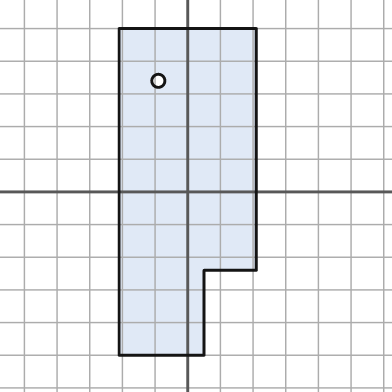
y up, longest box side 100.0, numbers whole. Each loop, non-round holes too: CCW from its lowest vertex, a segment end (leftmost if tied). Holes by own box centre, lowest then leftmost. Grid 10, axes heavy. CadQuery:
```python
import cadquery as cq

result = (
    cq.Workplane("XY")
    .moveTo(-21.0, -50.0)
    .lineTo(5.0, -50.0)
    .lineTo(5.0, -24.0)
    .lineTo(21.0, -24.0)
    .lineTo(21.0, 50.0)
    .lineTo(-21.0, 50.0)
    .close()
    .moveTo(-9.0, 34.0)
    .circle(2.0)
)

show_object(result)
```